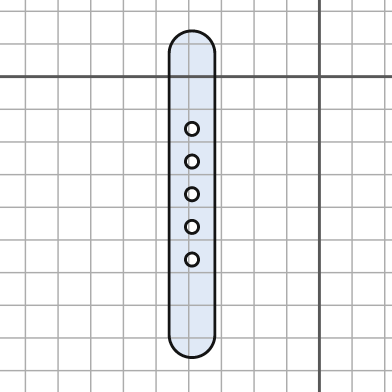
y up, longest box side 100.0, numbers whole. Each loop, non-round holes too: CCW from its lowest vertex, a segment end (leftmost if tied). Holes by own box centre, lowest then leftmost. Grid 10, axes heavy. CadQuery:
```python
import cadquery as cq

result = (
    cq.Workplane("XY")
    .moveTo(-46.0, -79.0)
    .threePointArc((-39.0, -86.0), (-32.0, -79.0))
    .lineTo(-32.0, 7.0)
    .threePointArc((-39.0, 14.0), (-46.0, 7.0))
    .close()
    .moveTo(-39.0, -56.0)
    .circle(2.0)
    .moveTo(-39.0, -46.0)
    .circle(2.0)
    .moveTo(-39.0, -36.0)
    .circle(2.0)
    .moveTo(-39.0, -26.0)
    .circle(2.0)
    .moveTo(-39.0, -16.0)
    .circle(2.0)
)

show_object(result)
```